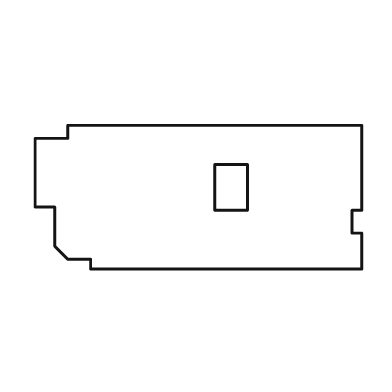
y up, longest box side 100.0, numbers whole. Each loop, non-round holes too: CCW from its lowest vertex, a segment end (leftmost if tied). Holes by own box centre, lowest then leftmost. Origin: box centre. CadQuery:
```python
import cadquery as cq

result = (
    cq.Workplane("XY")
    .moveTo(-33.0, -22.0)
    .lineTo(50.0, -22.0)
    .lineTo(50.0, -11.0)
    .lineTo(47.0, -11.0)
    .lineTo(47.0, -4.0)
    .lineTo(50.0, -4.0)
    .lineTo(50.0, 22.0)
    .lineTo(-40.0, 22.0)
    .lineTo(-40.0, 18.0)
    .lineTo(-50.0, 18.0)
    .lineTo(-50.0, -3.0)
    .lineTo(-44.0, -3.0)
    .lineTo(-44.0, -15.0)
    .lineTo(-40.0, -19.0)
    .lineTo(-33.0, -19.0)
    .close()
    .moveTo(5.0, -4.0)
    .lineTo(15.0, -4.0)
    .lineTo(15.0, 10.0)
    .lineTo(5.0, 10.0)
    .close()
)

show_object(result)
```